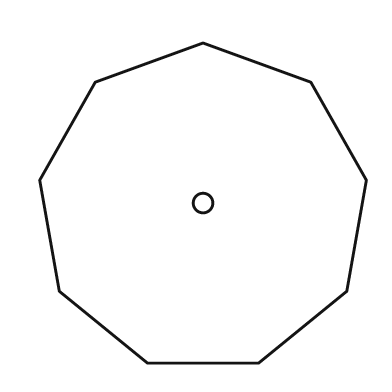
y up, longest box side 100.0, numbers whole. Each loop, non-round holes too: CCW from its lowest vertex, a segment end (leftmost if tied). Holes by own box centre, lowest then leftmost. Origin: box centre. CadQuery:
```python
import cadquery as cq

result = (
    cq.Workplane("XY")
    .moveTo(-17.0, -49.0)
    .lineTo(17.0, -49.0)
    .lineTo(44.0, -27.0)
    .lineTo(50.0, 7.0)
    .lineTo(33.0, 37.0)
    .lineTo(0.0, 49.0)
    .lineTo(-33.0, 37.0)
    .lineTo(-50.0, 7.0)
    .lineTo(-44.0, -27.0)
    .close()
    .moveTo(0.0, 0.0)
    .circle(3.0)
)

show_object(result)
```